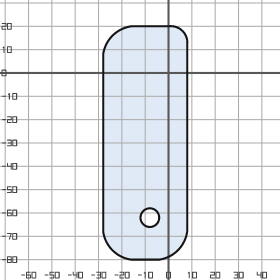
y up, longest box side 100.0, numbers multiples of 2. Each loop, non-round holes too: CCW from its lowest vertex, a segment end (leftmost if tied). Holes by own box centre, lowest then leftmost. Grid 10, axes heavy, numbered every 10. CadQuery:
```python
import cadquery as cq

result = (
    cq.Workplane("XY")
    .moveTo(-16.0, -80.0)
    .lineTo(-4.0, -80.0)
    .threePointArc((4.0, -76.0), (8.0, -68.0))
    .lineTo(8.0, 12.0)
    .threePointArc((6.0, 18.0), (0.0, 20.0))
    .lineTo(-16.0, 20.0)
    .threePointArc((-24.0, 16.0), (-28.0, 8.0))
    .lineTo(-28.0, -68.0)
    .threePointArc((-24.0, -76.0), (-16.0, -80.0))
    .close()
    .moveTo(-8.0, -62.0)
    .circle(4.0)
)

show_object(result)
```